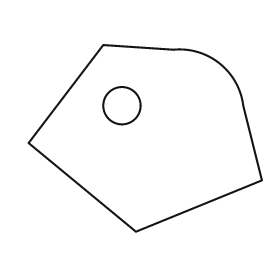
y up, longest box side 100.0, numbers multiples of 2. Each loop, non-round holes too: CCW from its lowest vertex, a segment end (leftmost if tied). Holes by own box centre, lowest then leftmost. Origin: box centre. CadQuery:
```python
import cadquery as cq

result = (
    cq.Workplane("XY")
    .moveTo(-4.0, -40.0)
    .lineTo(50.0, -18.0)
    .lineTo(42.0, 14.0)
    .threePointArc((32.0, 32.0), (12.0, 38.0))
    .lineTo(-18.0, 40.0)
    .lineTo(-50.0, -2.0)
    .close()
    .moveTo(-10.0, 14.0)
    .circle(8.0)
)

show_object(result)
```